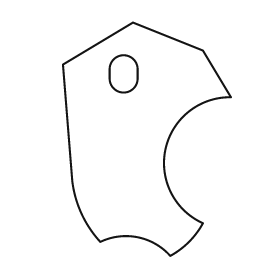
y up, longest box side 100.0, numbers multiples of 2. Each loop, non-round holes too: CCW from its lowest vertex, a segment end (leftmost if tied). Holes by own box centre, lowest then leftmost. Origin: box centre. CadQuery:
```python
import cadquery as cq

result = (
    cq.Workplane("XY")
    .moveTo(10.0, -50.0)
    .threePointArc((18.0, -44.0), (24.0, -36.0))
    .threePointArc((8.0, -4.0), (36.0, 18.0))
    .lineTo(24.0, 38.0)
    .lineTo(-6.0, 50.0)
    .lineTo(-36.0, 32.0)
    .lineTo(-32.0, -18.0)
    .threePointArc((-28.0, -32.0), (-20.0, -44.0))
    .threePointArc((-4.0, -42.0), (10.0, -50.0))
    .close()
    .moveTo(-16.0, 26.0)
    .threePointArc((-10.0, 20.0), (-4.0, 26.0))
    .lineTo(-4.0, 30.0)
    .threePointArc((-10.0, 36.0), (-16.0, 30.0))
    .close()
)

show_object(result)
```